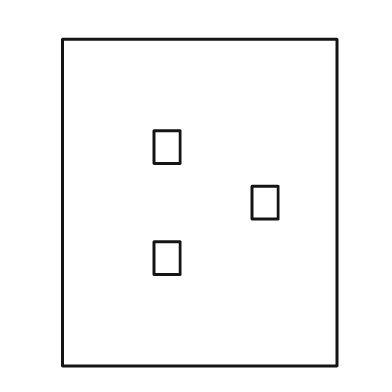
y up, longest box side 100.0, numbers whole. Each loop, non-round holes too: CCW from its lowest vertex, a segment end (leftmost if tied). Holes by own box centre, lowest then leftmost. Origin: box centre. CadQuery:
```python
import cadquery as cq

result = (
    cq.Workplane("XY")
    .moveTo(-42.0, -50.0)
    .lineTo(42.0, -50.0)
    .lineTo(42.0, 50.0)
    .lineTo(-42.0, 50.0)
    .close()
    .moveTo(-14.0, -22.0)
    .lineTo(-6.0, -22.0)
    .lineTo(-6.0, -12.0)
    .lineTo(-14.0, -12.0)
    .close()
    .moveTo(16.0, -5.0)
    .lineTo(24.0, -5.0)
    .lineTo(24.0, 5.0)
    .lineTo(16.0, 5.0)
    .close()
    .moveTo(-14.0, 12.0)
    .lineTo(-6.0, 12.0)
    .lineTo(-6.0, 22.0)
    .lineTo(-14.0, 22.0)
    .close()
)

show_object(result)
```